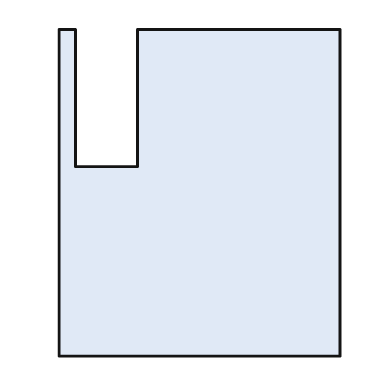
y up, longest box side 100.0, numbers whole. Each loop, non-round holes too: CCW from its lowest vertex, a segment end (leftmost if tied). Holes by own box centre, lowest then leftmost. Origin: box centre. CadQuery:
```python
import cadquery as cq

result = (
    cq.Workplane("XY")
    .moveTo(-43.0, -50.0)
    .lineTo(43.0, -50.0)
    .lineTo(43.0, 50.0)
    .lineTo(-19.0, 50.0)
    .lineTo(-19.0, 8.0)
    .lineTo(-38.0, 8.0)
    .lineTo(-38.0, 50.0)
    .lineTo(-43.0, 50.0)
    .close()
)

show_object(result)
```